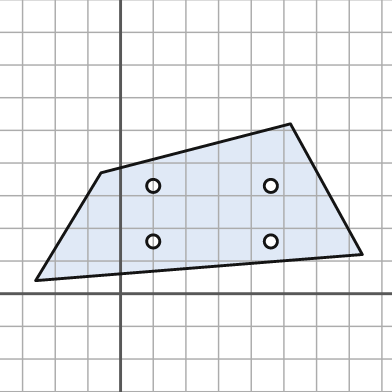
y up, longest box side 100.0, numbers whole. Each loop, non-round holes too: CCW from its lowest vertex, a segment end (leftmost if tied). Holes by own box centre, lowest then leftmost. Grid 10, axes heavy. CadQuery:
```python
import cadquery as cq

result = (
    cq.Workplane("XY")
    .moveTo(-26.0, 4.0)
    .lineTo(74.0, 12.0)
    .lineTo(52.0, 52.0)
    .lineTo(-6.0, 37.0)
    .close()
    .moveTo(10.0, 16.0)
    .circle(2.0)
    .moveTo(46.0, 16.0)
    .circle(2.0)
    .moveTo(10.0, 33.0)
    .circle(2.0)
    .moveTo(46.0, 33.0)
    .circle(2.0)
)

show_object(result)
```